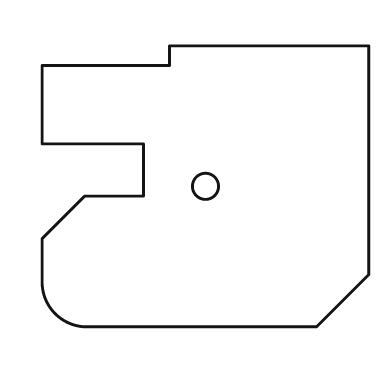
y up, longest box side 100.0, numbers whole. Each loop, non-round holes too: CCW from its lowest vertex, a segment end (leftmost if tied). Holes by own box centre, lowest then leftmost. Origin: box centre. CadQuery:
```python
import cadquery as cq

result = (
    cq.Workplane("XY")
    .moveTo(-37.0, -43.0)
    .lineTo(34.0, -43.0)
    .lineTo(50.0, -27.0)
    .lineTo(50.0, 43.0)
    .lineTo(-11.0, 43.0)
    .lineTo(-11.0, 37.0)
    .lineTo(-50.0, 37.0)
    .lineTo(-50.0, 13.0)
    .lineTo(-19.0, 13.0)
    .lineTo(-19.0, -3.0)
    .lineTo(-37.0, -3.0)
    .lineTo(-50.0, -16.0)
    .lineTo(-50.0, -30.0)
    .threePointArc((-46.0, -39.0), (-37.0, -43.0))
    .close()
    .moveTo(0.0, 0.0)
    .circle(4.0)
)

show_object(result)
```